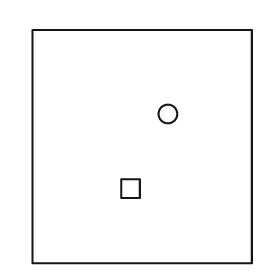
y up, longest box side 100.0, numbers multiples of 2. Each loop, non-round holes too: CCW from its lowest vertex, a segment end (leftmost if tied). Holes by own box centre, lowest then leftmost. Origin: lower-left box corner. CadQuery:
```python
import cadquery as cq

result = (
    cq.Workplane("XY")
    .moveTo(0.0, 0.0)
    .lineTo(94.0, 0.0)
    .lineTo(94.0, 100.0)
    .lineTo(0.0, 100.0)
    .close()
    .moveTo(38.0, 28.0)
    .lineTo(46.0, 28.0)
    .lineTo(46.0, 36.0)
    .lineTo(38.0, 36.0)
    .close()
    .moveTo(58.0, 64.0)
    .circle(4.0)
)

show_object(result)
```